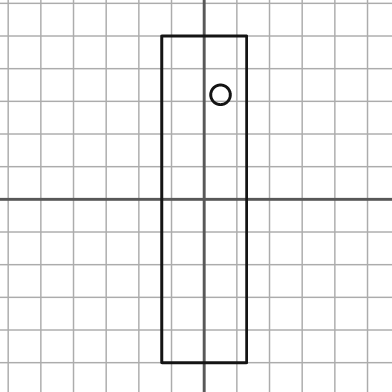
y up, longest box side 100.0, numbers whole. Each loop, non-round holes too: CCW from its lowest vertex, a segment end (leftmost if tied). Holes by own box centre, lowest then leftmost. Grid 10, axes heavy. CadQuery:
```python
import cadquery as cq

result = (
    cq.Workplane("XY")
    .moveTo(-13.0, -50.0)
    .lineTo(13.0, -50.0)
    .lineTo(13.0, 50.0)
    .lineTo(-13.0, 50.0)
    .close()
    .moveTo(5.0, 32.0)
    .circle(3.0)
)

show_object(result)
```